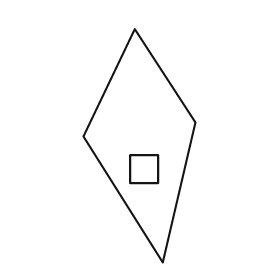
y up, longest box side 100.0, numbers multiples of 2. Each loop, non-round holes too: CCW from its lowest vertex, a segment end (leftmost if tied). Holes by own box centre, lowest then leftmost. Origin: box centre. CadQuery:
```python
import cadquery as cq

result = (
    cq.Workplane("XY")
    .moveTo(10.0, -50.0)
    .lineTo(24.0, 10.0)
    .lineTo(-2.0, 50.0)
    .lineTo(-24.0, 4.0)
    .close()
    .moveTo(-4.0, -16.0)
    .lineTo(8.0, -16.0)
    .lineTo(8.0, -4.0)
    .lineTo(-4.0, -4.0)
    .close()
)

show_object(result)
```